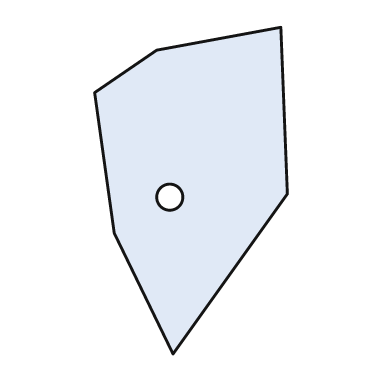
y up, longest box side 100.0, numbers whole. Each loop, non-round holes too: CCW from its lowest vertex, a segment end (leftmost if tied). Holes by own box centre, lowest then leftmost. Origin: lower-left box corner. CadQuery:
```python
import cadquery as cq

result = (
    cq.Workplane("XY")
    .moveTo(24.0, 0.0)
    .lineTo(59.0, 49.0)
    .lineTo(57.0, 100.0)
    .lineTo(19.0, 93.0)
    .lineTo(0.0, 80.0)
    .lineTo(6.0, 37.0)
    .close()
    .moveTo(23.0, 48.0)
    .circle(4.0)
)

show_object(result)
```